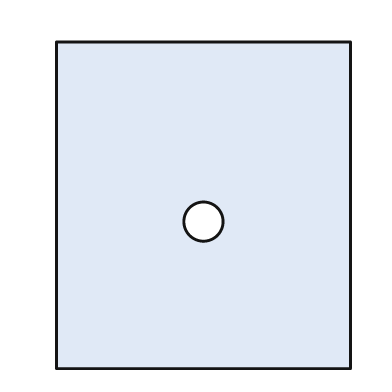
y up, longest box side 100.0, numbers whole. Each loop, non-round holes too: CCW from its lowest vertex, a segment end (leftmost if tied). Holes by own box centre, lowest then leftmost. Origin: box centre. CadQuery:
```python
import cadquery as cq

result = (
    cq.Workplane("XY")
    .moveTo(-45.0, -50.0)
    .lineTo(45.0, -50.0)
    .lineTo(45.0, 50.0)
    .lineTo(-45.0, 50.0)
    .close()
    .moveTo(0.0, -5.0)
    .circle(6.0)
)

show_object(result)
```